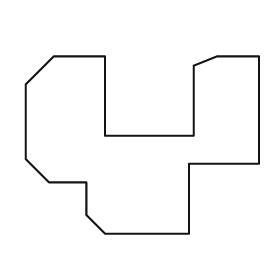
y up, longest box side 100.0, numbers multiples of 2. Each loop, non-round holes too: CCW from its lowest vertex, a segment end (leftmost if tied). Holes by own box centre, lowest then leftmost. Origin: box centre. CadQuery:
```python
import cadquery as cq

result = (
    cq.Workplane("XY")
    .moveTo(-16.0, -38.0)
    .lineTo(20.0, -38.0)
    .lineTo(20.0, -8.0)
    .lineTo(50.0, -8.0)
    .lineTo(50.0, 38.0)
    .lineTo(32.0, 38.0)
    .lineTo(22.0, 34.0)
    .lineTo(22.0, 4.0)
    .lineTo(-16.0, 4.0)
    .lineTo(-16.0, 38.0)
    .lineTo(-38.0, 38.0)
    .lineTo(-50.0, 26.0)
    .lineTo(-50.0, -6.0)
    .lineTo(-40.0, -16.0)
    .lineTo(-24.0, -16.0)
    .lineTo(-24.0, -30.0)
    .close()
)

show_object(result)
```